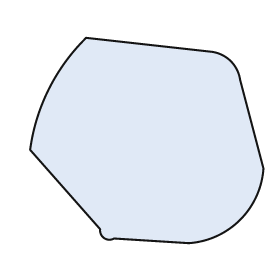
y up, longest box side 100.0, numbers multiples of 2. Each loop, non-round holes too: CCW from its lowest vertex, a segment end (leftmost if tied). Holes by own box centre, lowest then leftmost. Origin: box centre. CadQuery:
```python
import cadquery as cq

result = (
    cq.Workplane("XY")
    .moveTo(18.0, -44.0)
    .threePointArc((40.0, -34.0), (50.0, -12.0))
    .lineTo(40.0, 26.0)
    .threePointArc((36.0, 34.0), (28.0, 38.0))
    .lineTo(-26.0, 44.0)
    .threePointArc((-42.0, 22.0), (-50.0, -4.0))
    .lineTo(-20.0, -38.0)
    .threePointArc((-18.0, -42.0), (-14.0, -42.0))
    .close()
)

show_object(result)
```